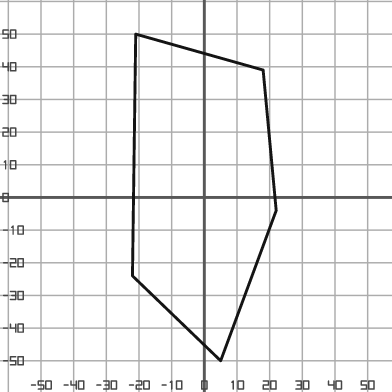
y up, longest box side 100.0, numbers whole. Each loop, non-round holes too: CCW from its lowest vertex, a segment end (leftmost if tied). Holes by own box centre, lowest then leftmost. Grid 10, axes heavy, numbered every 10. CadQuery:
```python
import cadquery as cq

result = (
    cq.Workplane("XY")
    .moveTo(5.0, -50.0)
    .lineTo(22.0, -4.0)
    .lineTo(18.0, 39.0)
    .lineTo(-21.0, 50.0)
    .lineTo(-22.0, -24.0)
    .close()
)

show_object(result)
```